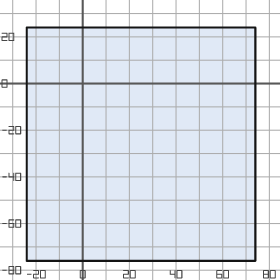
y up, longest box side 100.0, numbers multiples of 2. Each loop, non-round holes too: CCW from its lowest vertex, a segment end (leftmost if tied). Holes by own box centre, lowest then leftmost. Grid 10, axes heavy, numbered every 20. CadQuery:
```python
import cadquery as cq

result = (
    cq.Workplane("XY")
    .moveTo(-24.0, -76.0)
    .lineTo(74.0, -76.0)
    .lineTo(74.0, 24.0)
    .lineTo(-24.0, 24.0)
    .close()
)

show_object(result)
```